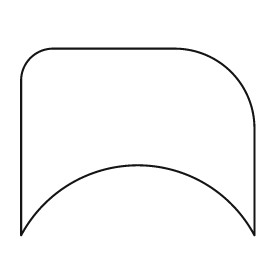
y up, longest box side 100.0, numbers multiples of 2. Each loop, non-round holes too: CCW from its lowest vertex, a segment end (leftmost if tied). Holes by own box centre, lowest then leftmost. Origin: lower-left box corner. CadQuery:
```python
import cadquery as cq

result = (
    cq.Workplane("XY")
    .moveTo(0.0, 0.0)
    .threePointArc((50.0, 30.0), (100.0, 0.0))
    .lineTo(100.0, 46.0)
    .threePointArc((90.0, 70.0), (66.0, 80.0))
    .lineTo(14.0, 80.0)
    .threePointArc((4.0, 76.0), (0.0, 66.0))
    .close()
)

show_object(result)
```